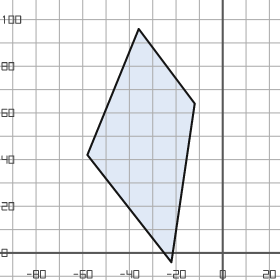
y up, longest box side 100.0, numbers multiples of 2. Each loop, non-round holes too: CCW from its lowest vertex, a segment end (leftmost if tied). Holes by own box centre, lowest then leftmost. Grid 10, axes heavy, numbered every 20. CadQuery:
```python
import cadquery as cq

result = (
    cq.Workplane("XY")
    .moveTo(-22.0, -4.0)
    .lineTo(-12.0, 64.0)
    .lineTo(-36.0, 96.0)
    .lineTo(-58.0, 42.0)
    .close()
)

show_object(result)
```